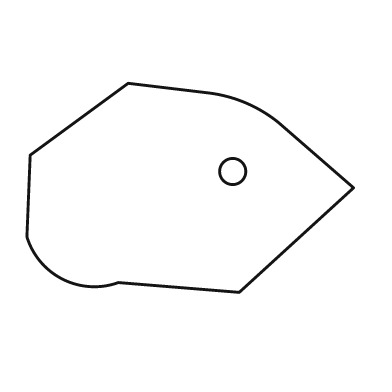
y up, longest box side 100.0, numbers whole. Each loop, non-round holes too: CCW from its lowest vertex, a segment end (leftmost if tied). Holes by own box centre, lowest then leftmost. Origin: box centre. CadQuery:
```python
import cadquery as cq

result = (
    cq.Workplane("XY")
    .moveTo(15.0, -32.0)
    .lineTo(50.0, 0.0)
    .lineTo(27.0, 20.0)
    .threePointArc((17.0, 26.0), (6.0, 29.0))
    .lineTo(-19.0, 32.0)
    .lineTo(-49.0, 10.0)
    .lineTo(-50.0, -15.0)
    .threePointArc((-39.0, -28.0), (-22.0, -29.0))
    .close()
    .moveTo(13.0, 5.0)
    .circle(4.0)
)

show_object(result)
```